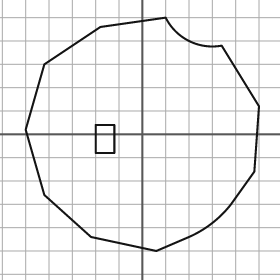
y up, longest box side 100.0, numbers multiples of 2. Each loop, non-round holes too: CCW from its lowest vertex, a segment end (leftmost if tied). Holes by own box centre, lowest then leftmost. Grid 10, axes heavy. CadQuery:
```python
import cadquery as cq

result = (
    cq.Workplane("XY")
    .moveTo(6.0, -50.0)
    .lineTo(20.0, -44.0)
    .threePointArc((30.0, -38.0), (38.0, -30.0))
    .lineTo(48.0, -16.0)
    .lineTo(50.0, 12.0)
    .lineTo(34.0, 38.0)
    .threePointArc((20.0, 40.0), (10.0, 50.0))
    .lineTo(-18.0, 46.0)
    .lineTo(-42.0, 30.0)
    .lineTo(-50.0, 2.0)
    .lineTo(-42.0, -26.0)
    .lineTo(-22.0, -44.0)
    .close()
    .moveTo(-20.0, -8.0)
    .lineTo(-12.0, -8.0)
    .lineTo(-12.0, 4.0)
    .lineTo(-20.0, 4.0)
    .close()
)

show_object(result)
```